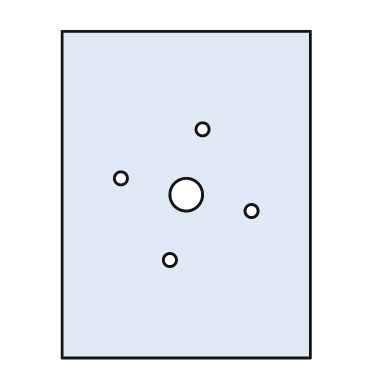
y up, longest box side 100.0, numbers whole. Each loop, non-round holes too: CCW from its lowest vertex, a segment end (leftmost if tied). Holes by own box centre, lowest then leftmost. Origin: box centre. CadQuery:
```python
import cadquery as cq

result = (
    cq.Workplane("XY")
    .moveTo(-38.0, -50.0)
    .lineTo(38.0, -50.0)
    .lineTo(38.0, 50.0)
    .lineTo(-38.0, 50.0)
    .close()
    .moveTo(-5.0, -20.0)
    .circle(2.0)
    .moveTo(20.0, -5.0)
    .circle(2.0)
    .moveTo(0.0, 0.0)
    .circle(5.0)
    .moveTo(-20.0, 5.0)
    .circle(2.0)
    .moveTo(5.0, 20.0)
    .circle(2.0)
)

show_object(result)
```